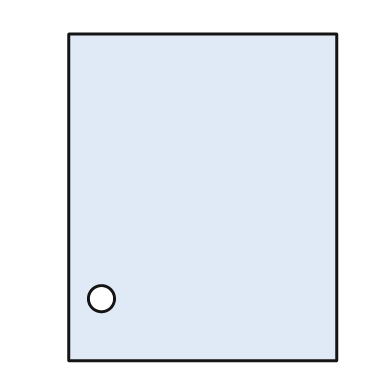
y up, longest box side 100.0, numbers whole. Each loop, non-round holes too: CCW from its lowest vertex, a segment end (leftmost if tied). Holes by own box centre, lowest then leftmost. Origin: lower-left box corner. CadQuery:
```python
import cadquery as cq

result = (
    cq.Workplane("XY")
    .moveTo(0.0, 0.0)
    .lineTo(82.0, 0.0)
    .lineTo(82.0, 100.0)
    .lineTo(0.0, 100.0)
    .close()
    .moveTo(10.0, 19.0)
    .circle(4.0)
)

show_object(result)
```